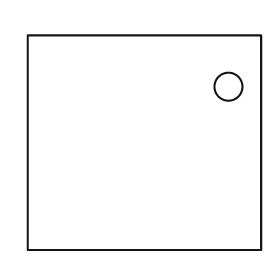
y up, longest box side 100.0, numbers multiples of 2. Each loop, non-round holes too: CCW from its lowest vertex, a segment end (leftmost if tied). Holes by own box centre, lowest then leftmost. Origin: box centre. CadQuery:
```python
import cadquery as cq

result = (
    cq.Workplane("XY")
    .moveTo(-50.0, -46.0)
    .lineTo(50.0, -46.0)
    .lineTo(50.0, 46.0)
    .lineTo(-50.0, 46.0)
    .close()
    .moveTo(36.0, 24.0)
    .circle(6.0)
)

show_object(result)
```